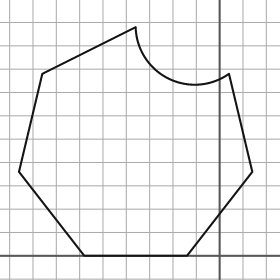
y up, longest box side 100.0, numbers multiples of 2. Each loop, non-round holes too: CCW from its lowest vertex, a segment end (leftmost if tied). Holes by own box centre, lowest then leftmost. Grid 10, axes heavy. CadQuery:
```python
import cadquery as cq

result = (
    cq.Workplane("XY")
    .moveTo(-58.0, 0.0)
    .lineTo(-14.0, 0.0)
    .lineTo(14.0, 36.0)
    .lineTo(4.0, 78.0)
    .threePointArc((-22.0, 76.0), (-36.0, 98.0))
    .lineTo(-76.0, 78.0)
    .lineTo(-86.0, 36.0)
    .close()
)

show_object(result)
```